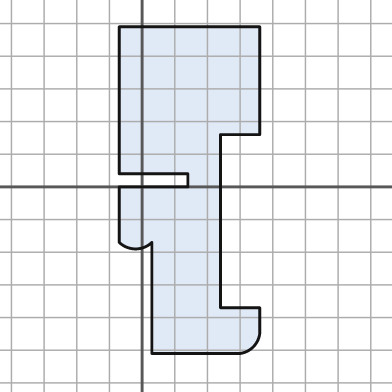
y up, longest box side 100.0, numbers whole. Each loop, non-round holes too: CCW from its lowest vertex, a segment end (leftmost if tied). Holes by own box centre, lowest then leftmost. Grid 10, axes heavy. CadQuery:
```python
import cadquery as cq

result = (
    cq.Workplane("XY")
    .moveTo(3.0, -51.0)
    .lineTo(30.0, -51.0)
    .threePointArc((34.0, -49.0), (36.0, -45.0))
    .lineTo(36.0, -37.0)
    .lineTo(24.0, -37.0)
    .lineTo(24.0, 16.0)
    .lineTo(36.0, 16.0)
    .lineTo(36.0, 49.0)
    .lineTo(-7.0, 49.0)
    .lineTo(-7.0, 4.0)
    .lineTo(14.0, 4.0)
    .lineTo(14.0, 0.0)
    .lineTo(-7.0, 0.0)
    .lineTo(-7.0, -17.0)
    .threePointArc((-2.0, -19.0), (3.0, -17.0))
    .close()
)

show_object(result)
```